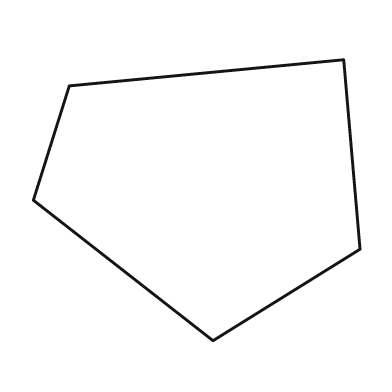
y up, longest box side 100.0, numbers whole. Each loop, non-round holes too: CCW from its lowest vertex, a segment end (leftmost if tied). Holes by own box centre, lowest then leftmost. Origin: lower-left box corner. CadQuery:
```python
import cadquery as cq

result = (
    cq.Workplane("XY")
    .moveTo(55.0, 0.0)
    .lineTo(100.0, 28.0)
    .lineTo(95.0, 86.0)
    .lineTo(11.0, 78.0)
    .lineTo(0.0, 43.0)
    .close()
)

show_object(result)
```